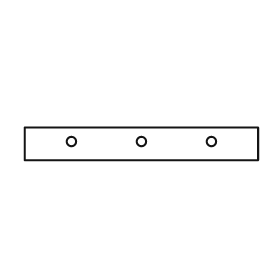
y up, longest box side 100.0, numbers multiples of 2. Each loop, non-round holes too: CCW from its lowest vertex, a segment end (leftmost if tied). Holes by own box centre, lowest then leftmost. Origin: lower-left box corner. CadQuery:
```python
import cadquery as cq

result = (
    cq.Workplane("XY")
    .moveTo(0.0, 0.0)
    .lineTo(100.0, 0.0)
    .lineTo(100.0, 14.0)
    .lineTo(0.0, 14.0)
    .close()
    .moveTo(20.0, 8.0)
    .circle(2.0)
    .moveTo(50.0, 8.0)
    .circle(2.0)
    .moveTo(80.0, 8.0)
    .circle(2.0)
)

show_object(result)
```